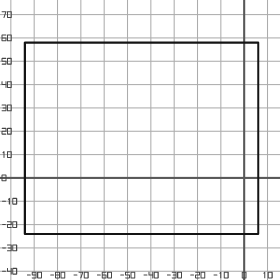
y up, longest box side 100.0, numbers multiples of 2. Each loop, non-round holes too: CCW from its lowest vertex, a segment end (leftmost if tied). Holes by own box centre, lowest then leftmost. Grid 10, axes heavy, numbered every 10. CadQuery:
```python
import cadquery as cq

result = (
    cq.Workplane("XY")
    .moveTo(-94.0, -24.0)
    .lineTo(6.0, -24.0)
    .lineTo(6.0, 58.0)
    .lineTo(-94.0, 58.0)
    .close()
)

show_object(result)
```